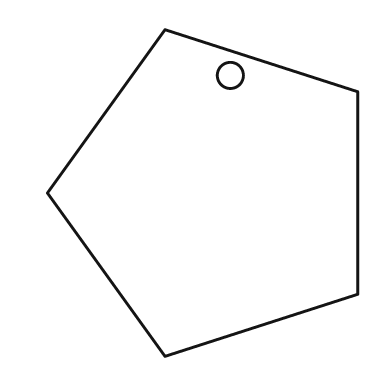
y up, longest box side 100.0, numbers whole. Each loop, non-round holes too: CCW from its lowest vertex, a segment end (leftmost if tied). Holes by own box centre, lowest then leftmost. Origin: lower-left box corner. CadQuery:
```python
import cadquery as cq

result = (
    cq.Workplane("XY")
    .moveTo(36.0, 0.0)
    .lineTo(95.0, 19.0)
    .lineTo(95.0, 81.0)
    .lineTo(36.0, 100.0)
    .lineTo(0.0, 50.0)
    .close()
    .moveTo(56.0, 86.0)
    .circle(4.0)
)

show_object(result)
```